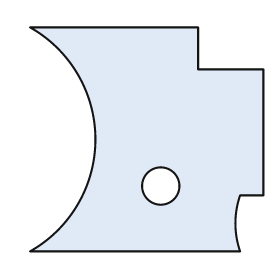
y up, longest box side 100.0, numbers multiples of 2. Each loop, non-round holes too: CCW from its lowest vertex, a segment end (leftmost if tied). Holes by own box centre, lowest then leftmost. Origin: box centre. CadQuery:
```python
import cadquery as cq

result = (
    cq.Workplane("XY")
    .moveTo(-50.0, -48.0)
    .lineTo(40.0, -48.0)
    .threePointArc((38.0, -36.0), (40.0, -24.0))
    .lineTo(50.0, -24.0)
    .lineTo(50.0, 30.0)
    .lineTo(22.0, 30.0)
    .lineTo(22.0, 48.0)
    .lineTo(-50.0, 48.0)
    .threePointArc((-22.0, 0.0), (-50.0, -48.0))
    .close()
    .moveTo(6.0, -20.0)
    .circle(8.0)
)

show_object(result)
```